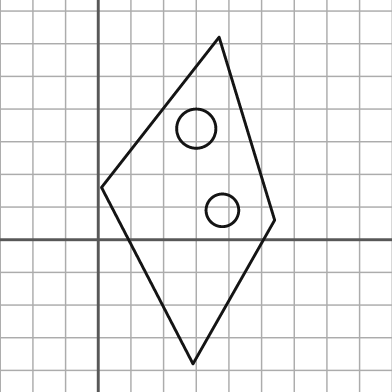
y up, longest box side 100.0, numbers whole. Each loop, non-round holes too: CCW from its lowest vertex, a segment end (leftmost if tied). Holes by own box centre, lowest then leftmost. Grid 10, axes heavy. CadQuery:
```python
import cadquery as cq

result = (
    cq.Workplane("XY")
    .moveTo(29.0, -38.0)
    .lineTo(54.0, 6.0)
    .lineTo(37.0, 62.0)
    .lineTo(1.0, 16.0)
    .close()
    .moveTo(38.0, 9.0)
    .circle(5.0)
    .moveTo(30.0, 34.0)
    .circle(6.0)
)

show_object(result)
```